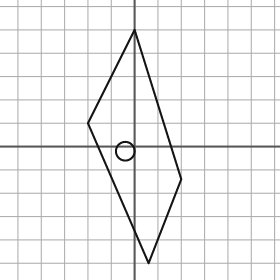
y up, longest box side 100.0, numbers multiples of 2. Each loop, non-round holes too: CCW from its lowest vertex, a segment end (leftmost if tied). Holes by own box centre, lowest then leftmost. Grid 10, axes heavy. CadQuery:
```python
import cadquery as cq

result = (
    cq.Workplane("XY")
    .moveTo(6.0, -50.0)
    .lineTo(20.0, -14.0)
    .lineTo(0.0, 50.0)
    .lineTo(-20.0, 10.0)
    .close()
    .moveTo(-4.0, -2.0)
    .circle(4.0)
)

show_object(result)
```